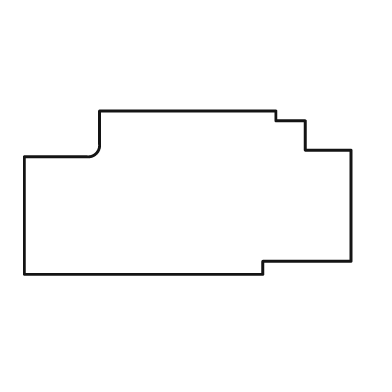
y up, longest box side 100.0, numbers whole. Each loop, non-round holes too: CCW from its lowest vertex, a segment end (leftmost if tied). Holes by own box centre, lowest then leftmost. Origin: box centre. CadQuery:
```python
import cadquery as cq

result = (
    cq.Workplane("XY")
    .moveTo(-50.0, -25.0)
    .lineTo(23.0, -25.0)
    .lineTo(23.0, -21.0)
    .lineTo(50.0, -21.0)
    .lineTo(50.0, 13.0)
    .lineTo(36.0, 13.0)
    .lineTo(36.0, 22.0)
    .lineTo(27.0, 22.0)
    .lineTo(27.0, 25.0)
    .lineTo(-27.0, 25.0)
    .lineTo(-27.0, 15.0)
    .threePointArc((-28.0, 12.0), (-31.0, 11.0))
    .lineTo(-50.0, 11.0)
    .close()
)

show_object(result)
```